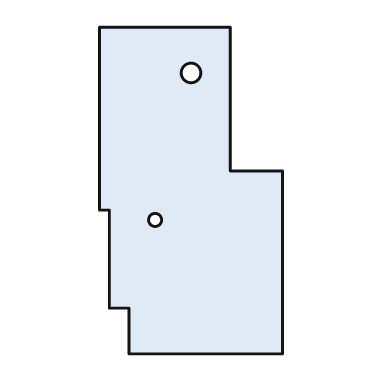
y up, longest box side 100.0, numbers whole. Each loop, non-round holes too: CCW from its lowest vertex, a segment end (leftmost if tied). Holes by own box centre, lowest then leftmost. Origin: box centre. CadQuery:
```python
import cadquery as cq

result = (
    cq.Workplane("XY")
    .moveTo(-19.0, -50.0)
    .lineTo(28.0, -50.0)
    .lineTo(28.0, 6.0)
    .lineTo(12.0, 6.0)
    .lineTo(12.0, 50.0)
    .lineTo(-28.0, 50.0)
    .lineTo(-28.0, -6.0)
    .lineTo(-25.0, -6.0)
    .lineTo(-25.0, -36.0)
    .lineTo(-19.0, -36.0)
    .close()
    .moveTo(-11.0, -9.0)
    .circle(2.0)
    .moveTo(0.0, 36.0)
    .circle(3.0)
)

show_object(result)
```